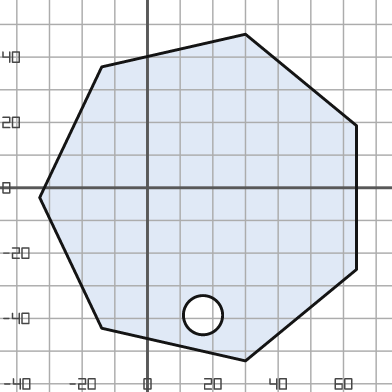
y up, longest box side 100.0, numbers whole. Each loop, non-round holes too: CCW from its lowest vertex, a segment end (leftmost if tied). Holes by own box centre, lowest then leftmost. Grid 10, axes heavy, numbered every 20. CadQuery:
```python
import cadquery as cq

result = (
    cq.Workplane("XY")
    .moveTo(30.0, -53.0)
    .lineTo(64.0, -25.0)
    .lineTo(64.0, 19.0)
    .lineTo(30.0, 47.0)
    .lineTo(-14.0, 37.0)
    .lineTo(-33.0, -3.0)
    .lineTo(-14.0, -43.0)
    .close()
    .moveTo(17.0, -39.0)
    .circle(6.0)
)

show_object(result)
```